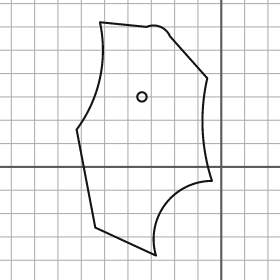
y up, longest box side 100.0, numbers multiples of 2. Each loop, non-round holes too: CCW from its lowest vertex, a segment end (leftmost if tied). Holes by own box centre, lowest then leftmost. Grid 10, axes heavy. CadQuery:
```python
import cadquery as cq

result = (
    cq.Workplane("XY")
    .moveTo(-28.0, -38.0)
    .threePointArc((-24.0, -16.0), (-4.0, -6.0))
    .threePointArc((-8.0, 16.0), (-6.0, 38.0))
    .lineTo(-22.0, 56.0)
    .threePointArc((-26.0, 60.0), (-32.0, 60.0))
    .lineTo(-52.0, 62.0)
    .threePointArc((-52.0, 38.0), (-62.0, 16.0))
    .lineTo(-54.0, -26.0)
    .close()
    .moveTo(-34.0, 30.0)
    .circle(2.0)
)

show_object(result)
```